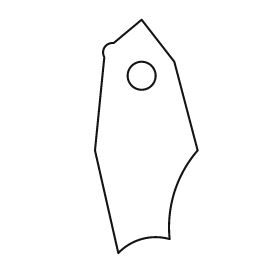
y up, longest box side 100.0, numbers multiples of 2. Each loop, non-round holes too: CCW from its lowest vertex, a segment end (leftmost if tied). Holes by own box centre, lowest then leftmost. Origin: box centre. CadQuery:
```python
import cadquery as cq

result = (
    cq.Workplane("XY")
    .moveTo(-12.0, -50.0)
    .threePointArc((-2.0, -44.0), (10.0, -44.0))
    .threePointArc((12.0, -24.0), (22.0, -6.0))
    .lineTo(12.0, 32.0)
    .lineTo(-2.0, 50.0)
    .lineTo(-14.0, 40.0)
    .threePointArc((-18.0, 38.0), (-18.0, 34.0))
    .lineTo(-22.0, -6.0)
    .close()
    .moveTo(-2.0, 26.0)
    .circle(6.0)
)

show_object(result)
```